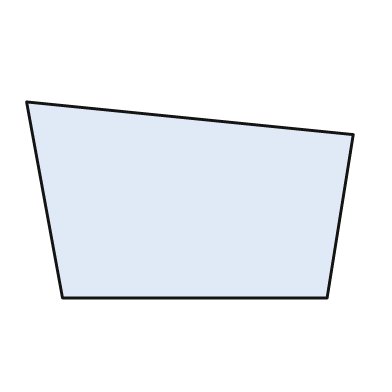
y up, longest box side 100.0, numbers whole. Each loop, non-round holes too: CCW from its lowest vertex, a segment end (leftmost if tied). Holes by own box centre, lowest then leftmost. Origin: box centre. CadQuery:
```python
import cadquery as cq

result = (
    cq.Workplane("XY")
    .moveTo(-39.0, -30.0)
    .lineTo(42.0, -30.0)
    .lineTo(50.0, 20.0)
    .lineTo(-50.0, 30.0)
    .close()
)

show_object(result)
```